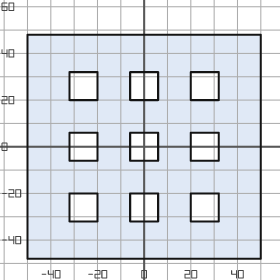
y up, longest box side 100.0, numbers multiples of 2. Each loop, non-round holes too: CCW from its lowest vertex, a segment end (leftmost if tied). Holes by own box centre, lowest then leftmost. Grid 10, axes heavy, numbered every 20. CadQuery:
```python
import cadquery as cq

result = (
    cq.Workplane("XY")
    .moveTo(-50.0, -48.0)
    .lineTo(50.0, -48.0)
    .lineTo(50.0, 48.0)
    .lineTo(-50.0, 48.0)
    .close()
    .moveTo(-32.0, -32.0)
    .lineTo(-20.0, -32.0)
    .lineTo(-20.0, -20.0)
    .lineTo(-32.0, -20.0)
    .close()
    .moveTo(-6.0, -32.0)
    .lineTo(6.0, -32.0)
    .lineTo(6.0, -20.0)
    .lineTo(-6.0, -20.0)
    .close()
    .moveTo(20.0, -32.0)
    .lineTo(32.0, -32.0)
    .lineTo(32.0, -20.0)
    .lineTo(20.0, -20.0)
    .close()
    .moveTo(-32.0, -6.0)
    .lineTo(-20.0, -6.0)
    .lineTo(-20.0, 6.0)
    .lineTo(-32.0, 6.0)
    .close()
    .moveTo(-6.0, -6.0)
    .lineTo(6.0, -6.0)
    .lineTo(6.0, 6.0)
    .lineTo(-6.0, 6.0)
    .close()
    .moveTo(20.0, -6.0)
    .lineTo(32.0, -6.0)
    .lineTo(32.0, 6.0)
    .lineTo(20.0, 6.0)
    .close()
    .moveTo(-32.0, 20.0)
    .lineTo(-20.0, 20.0)
    .lineTo(-20.0, 32.0)
    .lineTo(-32.0, 32.0)
    .close()
    .moveTo(-6.0, 20.0)
    .lineTo(6.0, 20.0)
    .lineTo(6.0, 32.0)
    .lineTo(-6.0, 32.0)
    .close()
    .moveTo(20.0, 20.0)
    .lineTo(32.0, 20.0)
    .lineTo(32.0, 32.0)
    .lineTo(20.0, 32.0)
    .close()
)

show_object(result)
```